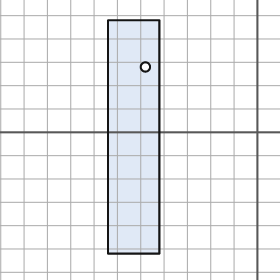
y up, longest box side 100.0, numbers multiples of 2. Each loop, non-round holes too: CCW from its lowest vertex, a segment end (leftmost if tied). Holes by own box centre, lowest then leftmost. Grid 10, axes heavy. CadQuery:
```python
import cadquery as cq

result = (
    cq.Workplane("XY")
    .moveTo(-64.0, -52.0)
    .lineTo(-42.0, -52.0)
    .lineTo(-42.0, 48.0)
    .lineTo(-64.0, 48.0)
    .close()
    .moveTo(-48.0, 28.0)
    .circle(2.0)
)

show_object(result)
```